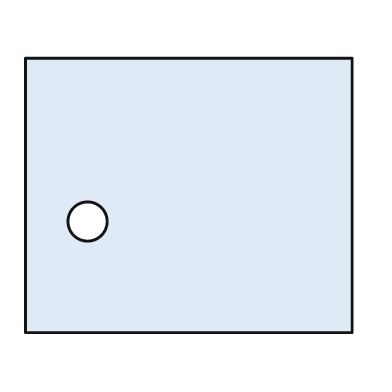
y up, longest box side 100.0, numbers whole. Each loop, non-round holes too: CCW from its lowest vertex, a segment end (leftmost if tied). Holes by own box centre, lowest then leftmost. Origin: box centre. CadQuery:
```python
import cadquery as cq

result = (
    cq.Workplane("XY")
    .moveTo(-50.0, -42.0)
    .lineTo(50.0, -42.0)
    .lineTo(50.0, 42.0)
    .lineTo(-50.0, 42.0)
    .close()
    .moveTo(-31.0, -8.0)
    .circle(6.0)
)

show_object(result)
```